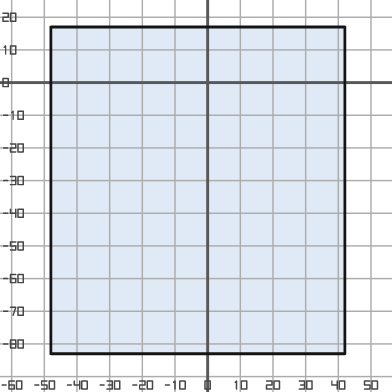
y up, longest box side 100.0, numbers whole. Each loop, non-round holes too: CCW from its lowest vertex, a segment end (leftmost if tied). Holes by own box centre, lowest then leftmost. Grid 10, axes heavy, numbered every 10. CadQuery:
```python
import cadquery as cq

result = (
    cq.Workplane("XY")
    .moveTo(-48.0, -83.0)
    .lineTo(42.0, -83.0)
    .lineTo(42.0, 17.0)
    .lineTo(-48.0, 17.0)
    .close()
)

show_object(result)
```